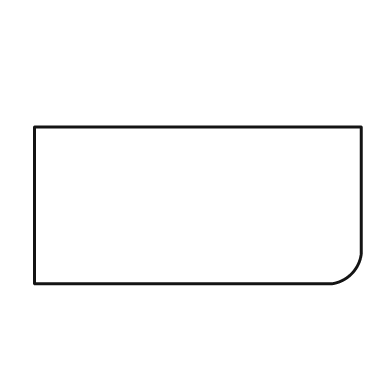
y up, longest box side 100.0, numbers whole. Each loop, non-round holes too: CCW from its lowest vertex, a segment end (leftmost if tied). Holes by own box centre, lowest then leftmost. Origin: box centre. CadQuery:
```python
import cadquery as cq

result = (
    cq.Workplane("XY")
    .moveTo(-50.0, -24.0)
    .lineTo(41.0, -24.0)
    .threePointArc((47.0, -21.0), (50.0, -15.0))
    .lineTo(50.0, 24.0)
    .lineTo(-50.0, 24.0)
    .close()
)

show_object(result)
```